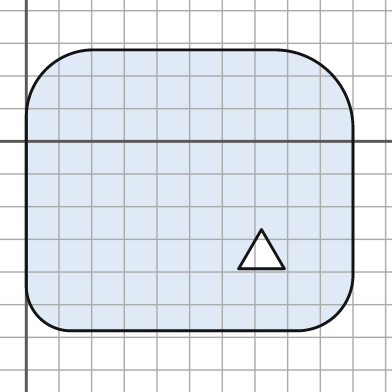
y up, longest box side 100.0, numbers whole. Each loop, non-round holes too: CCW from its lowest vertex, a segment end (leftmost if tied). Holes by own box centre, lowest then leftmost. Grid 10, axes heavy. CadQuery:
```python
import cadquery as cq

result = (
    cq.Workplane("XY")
    .moveTo(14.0, -58.0)
    .lineTo(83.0, -58.0)
    .threePointArc((95.0, -53.0), (100.0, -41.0))
    .lineTo(100.0, 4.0)
    .threePointArc((93.0, 21.0), (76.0, 28.0))
    .lineTo(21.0, 28.0)
    .threePointArc((6.0, 22.0), (0.0, 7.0))
    .lineTo(0.0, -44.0)
    .threePointArc((4.0, -54.0), (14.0, -58.0))
    .close()
    .moveTo(65.0, -39.0)
    .lineTo(79.0, -39.0)
    .lineTo(72.0, -27.0)
    .close()
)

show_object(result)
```